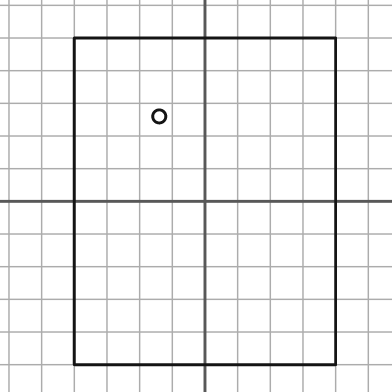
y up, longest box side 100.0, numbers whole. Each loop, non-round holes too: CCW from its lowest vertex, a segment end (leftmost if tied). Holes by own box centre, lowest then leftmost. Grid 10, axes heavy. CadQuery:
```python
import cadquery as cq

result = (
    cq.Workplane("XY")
    .moveTo(-40.0, -50.0)
    .lineTo(40.0, -50.0)
    .lineTo(40.0, 50.0)
    .lineTo(-40.0, 50.0)
    .close()
    .moveTo(-14.0, 26.0)
    .circle(2.0)
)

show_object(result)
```